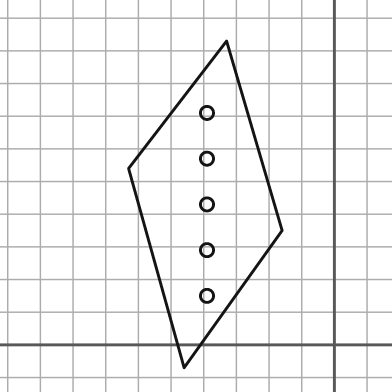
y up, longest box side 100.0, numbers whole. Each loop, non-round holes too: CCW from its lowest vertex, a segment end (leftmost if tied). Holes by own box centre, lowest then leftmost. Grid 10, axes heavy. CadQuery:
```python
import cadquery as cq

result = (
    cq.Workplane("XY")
    .moveTo(-46.0, -7.0)
    .lineTo(-16.0, 35.0)
    .lineTo(-33.0, 93.0)
    .lineTo(-63.0, 54.0)
    .close()
    .moveTo(-39.0, 15.0)
    .circle(2.0)
    .moveTo(-39.0, 29.0)
    .circle(2.0)
    .moveTo(-39.0, 43.0)
    .circle(2.0)
    .moveTo(-39.0, 57.0)
    .circle(2.0)
    .moveTo(-39.0, 71.0)
    .circle(2.0)
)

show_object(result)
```